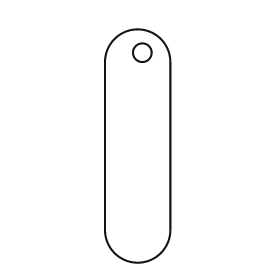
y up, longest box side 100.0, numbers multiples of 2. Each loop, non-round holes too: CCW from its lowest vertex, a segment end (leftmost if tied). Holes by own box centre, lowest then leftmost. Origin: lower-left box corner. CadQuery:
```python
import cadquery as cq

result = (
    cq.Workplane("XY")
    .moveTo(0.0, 14.0)
    .threePointArc((14.0, 0.0), (28.0, 14.0))
    .lineTo(28.0, 86.0)
    .threePointArc((14.0, 100.0), (0.0, 86.0))
    .close()
    .moveTo(16.0, 90.0)
    .circle(4.0)
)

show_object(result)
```